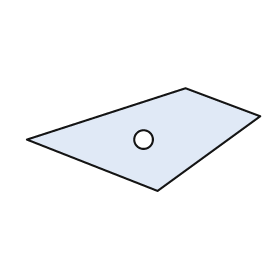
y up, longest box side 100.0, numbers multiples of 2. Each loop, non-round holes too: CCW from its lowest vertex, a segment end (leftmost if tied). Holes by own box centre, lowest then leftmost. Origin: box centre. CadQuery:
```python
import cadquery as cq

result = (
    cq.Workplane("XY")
    .moveTo(6.0, -22.0)
    .lineTo(50.0, 10.0)
    .lineTo(18.0, 22.0)
    .lineTo(-50.0, 0.0)
    .close()
    .moveTo(0.0, 0.0)
    .circle(4.0)
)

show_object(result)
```